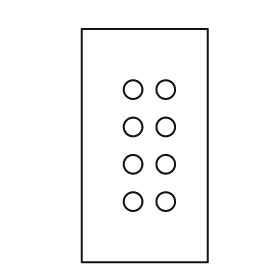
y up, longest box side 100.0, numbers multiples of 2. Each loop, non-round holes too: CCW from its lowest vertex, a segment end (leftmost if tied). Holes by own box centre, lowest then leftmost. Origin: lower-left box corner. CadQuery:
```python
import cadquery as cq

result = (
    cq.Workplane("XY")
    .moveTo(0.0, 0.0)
    .lineTo(54.0, 0.0)
    .lineTo(54.0, 100.0)
    .lineTo(0.0, 100.0)
    .close()
    .moveTo(22.0, 26.0)
    .circle(4.0)
    .moveTo(36.0, 26.0)
    .circle(4.0)
    .moveTo(22.0, 42.0)
    .circle(4.0)
    .moveTo(36.0, 42.0)
    .circle(4.0)
    .moveTo(22.0, 58.0)
    .circle(4.0)
    .moveTo(36.0, 58.0)
    .circle(4.0)
    .moveTo(22.0, 74.0)
    .circle(4.0)
    .moveTo(36.0, 74.0)
    .circle(4.0)
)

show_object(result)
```